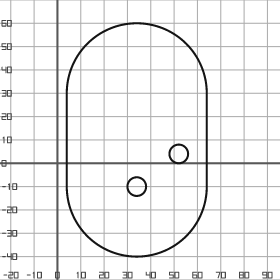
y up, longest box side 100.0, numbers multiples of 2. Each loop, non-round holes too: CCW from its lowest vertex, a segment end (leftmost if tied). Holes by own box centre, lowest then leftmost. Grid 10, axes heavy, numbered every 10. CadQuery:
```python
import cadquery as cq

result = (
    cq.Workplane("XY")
    .moveTo(4.0, -10.0)
    .threePointArc((34.0, -40.0), (64.0, -10.0))
    .lineTo(64.0, 30.0)
    .threePointArc((34.0, 60.0), (4.0, 30.0))
    .close()
    .moveTo(34.0, -10.0)
    .circle(4.0)
    .moveTo(52.0, 4.0)
    .circle(4.0)
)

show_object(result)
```